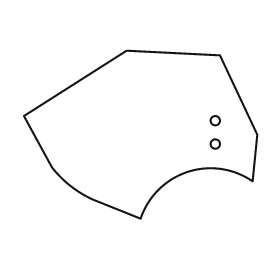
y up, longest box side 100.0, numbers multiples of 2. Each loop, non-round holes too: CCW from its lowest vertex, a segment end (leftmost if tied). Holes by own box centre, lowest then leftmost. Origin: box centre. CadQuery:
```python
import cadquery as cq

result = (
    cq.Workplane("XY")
    .moveTo(0.0, -36.0)
    .threePointArc((20.0, -16.0), (48.0, -20.0))
    .lineTo(50.0, 0.0)
    .lineTo(34.0, 34.0)
    .lineTo(-6.0, 36.0)
    .lineTo(-50.0, 8.0)
    .lineTo(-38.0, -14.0)
    .threePointArc((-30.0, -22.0), (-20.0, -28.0))
    .close()
    .moveTo(32.0, -4.0)
    .circle(2.0)
    .moveTo(32.0, 6.0)
    .circle(2.0)
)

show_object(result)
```